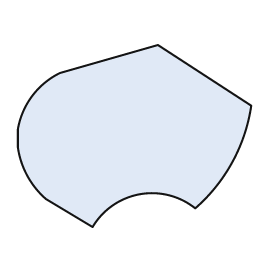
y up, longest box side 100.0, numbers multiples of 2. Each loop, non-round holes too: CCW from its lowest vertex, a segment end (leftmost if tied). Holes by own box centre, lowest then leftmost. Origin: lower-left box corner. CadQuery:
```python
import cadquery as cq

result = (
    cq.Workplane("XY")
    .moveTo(32.0, 0.0)
    .threePointArc((52.0, 14.0), (76.0, 8.0))
    .threePointArc((92.0, 28.0), (100.0, 52.0))
    .lineTo(60.0, 78.0)
    .lineTo(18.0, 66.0)
    .threePointArc((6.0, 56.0), (0.0, 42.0))
    .lineTo(0.0, 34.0)
    .threePointArc((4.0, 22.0), (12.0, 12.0))
    .close()
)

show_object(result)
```